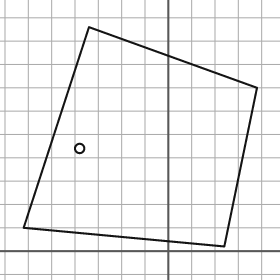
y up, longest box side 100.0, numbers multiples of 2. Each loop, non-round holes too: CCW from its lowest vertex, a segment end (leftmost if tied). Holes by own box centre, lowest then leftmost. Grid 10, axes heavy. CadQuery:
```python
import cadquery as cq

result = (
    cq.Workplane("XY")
    .moveTo(24.0, 2.0)
    .lineTo(38.0, 70.0)
    .lineTo(-34.0, 96.0)
    .lineTo(-62.0, 10.0)
    .close()
    .moveTo(-38.0, 44.0)
    .circle(2.0)
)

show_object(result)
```